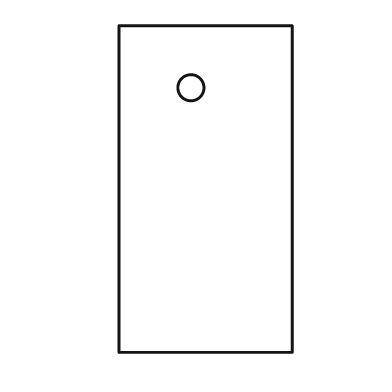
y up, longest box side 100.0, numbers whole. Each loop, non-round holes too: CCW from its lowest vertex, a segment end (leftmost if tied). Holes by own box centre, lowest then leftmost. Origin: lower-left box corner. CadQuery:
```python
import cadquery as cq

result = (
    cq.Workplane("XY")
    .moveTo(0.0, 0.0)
    .lineTo(53.0, 0.0)
    .lineTo(53.0, 100.0)
    .lineTo(0.0, 100.0)
    .close()
    .moveTo(22.0, 81.0)
    .circle(4.0)
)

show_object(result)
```